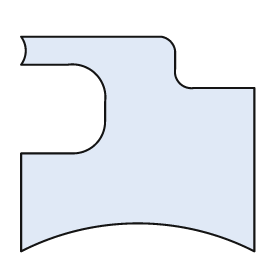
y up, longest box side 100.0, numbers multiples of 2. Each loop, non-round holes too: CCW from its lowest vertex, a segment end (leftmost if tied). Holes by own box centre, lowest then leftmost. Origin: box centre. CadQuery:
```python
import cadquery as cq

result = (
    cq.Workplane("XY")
    .moveTo(-50.0, -46.0)
    .threePointArc((0.0, -34.0), (50.0, -46.0))
    .lineTo(50.0, 24.0)
    .lineTo(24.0, 24.0)
    .threePointArc((18.0, 26.0), (16.0, 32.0))
    .lineTo(16.0, 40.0)
    .threePointArc((14.0, 44.0), (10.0, 46.0))
    .lineTo(-50.0, 46.0)
    .threePointArc((-48.0, 40.0), (-50.0, 34.0))
    .lineTo(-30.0, 34.0)
    .threePointArc((-18.0, 30.0), (-14.0, 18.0))
    .lineTo(-14.0, 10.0)
    .threePointArc((-18.0, 0.0), (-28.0, -4.0))
    .lineTo(-50.0, -4.0)
    .close()
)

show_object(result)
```